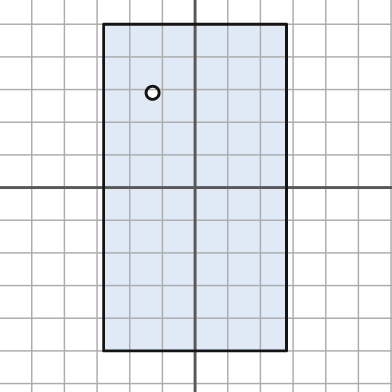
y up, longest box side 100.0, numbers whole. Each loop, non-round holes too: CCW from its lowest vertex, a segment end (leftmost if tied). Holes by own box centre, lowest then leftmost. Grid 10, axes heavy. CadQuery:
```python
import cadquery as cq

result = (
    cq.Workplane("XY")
    .moveTo(-28.0, -50.0)
    .lineTo(28.0, -50.0)
    .lineTo(28.0, 50.0)
    .lineTo(-28.0, 50.0)
    .close()
    .moveTo(-13.0, 29.0)
    .circle(2.0)
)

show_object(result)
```